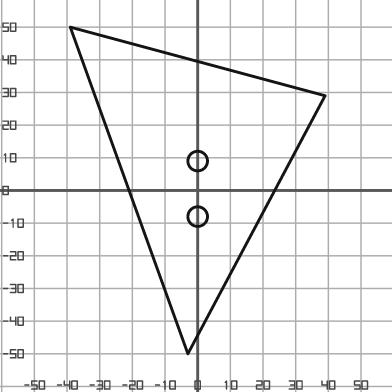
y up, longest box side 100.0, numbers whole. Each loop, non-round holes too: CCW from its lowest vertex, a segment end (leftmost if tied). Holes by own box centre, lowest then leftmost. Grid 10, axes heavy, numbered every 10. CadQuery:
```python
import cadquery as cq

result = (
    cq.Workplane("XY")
    .moveTo(-3.0, -50.0)
    .lineTo(39.0, 29.0)
    .lineTo(-39.0, 50.0)
    .close()
    .moveTo(0.0, -8.0)
    .circle(3.0)
    .moveTo(0.0, 9.0)
    .circle(3.0)
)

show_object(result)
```